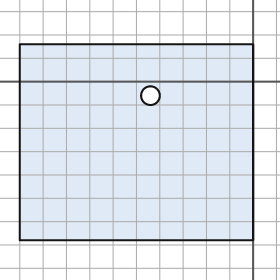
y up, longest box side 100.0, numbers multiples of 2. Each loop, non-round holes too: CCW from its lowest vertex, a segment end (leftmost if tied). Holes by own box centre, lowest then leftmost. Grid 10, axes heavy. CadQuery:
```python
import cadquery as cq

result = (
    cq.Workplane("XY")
    .moveTo(-100.0, -68.0)
    .lineTo(0.0, -68.0)
    .lineTo(0.0, 16.0)
    .lineTo(-100.0, 16.0)
    .close()
    .moveTo(-44.0, -6.0)
    .circle(4.0)
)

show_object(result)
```